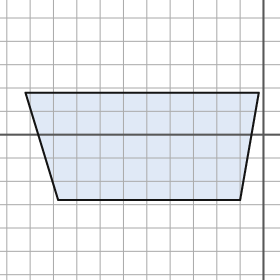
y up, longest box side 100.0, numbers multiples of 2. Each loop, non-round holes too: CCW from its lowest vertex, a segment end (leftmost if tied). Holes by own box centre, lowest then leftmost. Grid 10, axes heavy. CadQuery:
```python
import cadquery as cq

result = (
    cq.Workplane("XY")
    .moveTo(-88.0, -28.0)
    .lineTo(-10.0, -28.0)
    .lineTo(-2.0, 18.0)
    .lineTo(-102.0, 18.0)
    .close()
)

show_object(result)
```